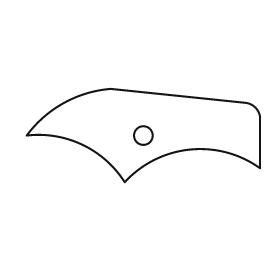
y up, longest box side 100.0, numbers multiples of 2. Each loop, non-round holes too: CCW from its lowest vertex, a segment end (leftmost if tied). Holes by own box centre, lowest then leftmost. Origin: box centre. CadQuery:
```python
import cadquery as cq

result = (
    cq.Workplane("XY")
    .moveTo(-8.0, -20.0)
    .threePointArc((20.0, -6.0), (50.0, -14.0))
    .lineTo(50.0, 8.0)
    .threePointArc((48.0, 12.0), (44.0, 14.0))
    .lineTo(-14.0, 20.0)
    .threePointArc((-34.0, 14.0), (-50.0, 0.0))
    .threePointArc((-26.0, -4.0), (-8.0, -20.0))
    .close()
    .moveTo(0.0, 0.0)
    .circle(4.0)
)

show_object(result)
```